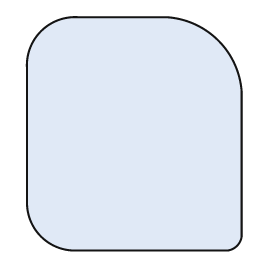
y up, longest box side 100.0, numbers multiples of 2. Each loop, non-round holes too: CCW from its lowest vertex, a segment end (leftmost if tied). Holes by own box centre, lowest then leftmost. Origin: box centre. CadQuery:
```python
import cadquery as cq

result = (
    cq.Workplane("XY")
    .moveTo(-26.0, -50.0)
    .lineTo(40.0, -50.0)
    .threePointArc((44.0, -48.0), (46.0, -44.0))
    .lineTo(46.0, 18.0)
    .threePointArc((36.0, 40.0), (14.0, 50.0))
    .lineTo(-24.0, 50.0)
    .threePointArc((-40.0, 44.0), (-46.0, 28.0))
    .lineTo(-46.0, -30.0)
    .threePointArc((-40.0, -44.0), (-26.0, -50.0))
    .close()
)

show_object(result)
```